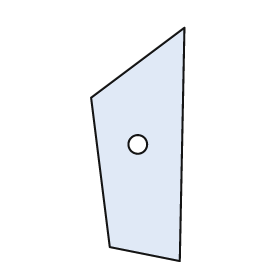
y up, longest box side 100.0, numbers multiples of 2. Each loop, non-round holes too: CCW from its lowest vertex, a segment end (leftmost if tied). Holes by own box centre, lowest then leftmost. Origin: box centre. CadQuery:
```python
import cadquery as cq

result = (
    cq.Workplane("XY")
    .moveTo(18.0, -50.0)
    .lineTo(20.0, 50.0)
    .lineTo(-20.0, 20.0)
    .lineTo(-12.0, -44.0)
    .close()
    .moveTo(0.0, 0.0)
    .circle(4.0)
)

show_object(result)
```